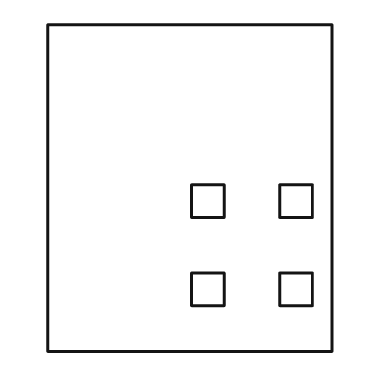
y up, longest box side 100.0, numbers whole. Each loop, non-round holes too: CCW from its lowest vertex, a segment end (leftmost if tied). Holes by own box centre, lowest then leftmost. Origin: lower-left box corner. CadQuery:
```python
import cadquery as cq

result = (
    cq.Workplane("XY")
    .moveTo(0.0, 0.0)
    .lineTo(87.0, 0.0)
    .lineTo(87.0, 100.0)
    .lineTo(0.0, 100.0)
    .close()
    .moveTo(44.0, 14.0)
    .lineTo(54.0, 14.0)
    .lineTo(54.0, 24.0)
    .lineTo(44.0, 24.0)
    .close()
    .moveTo(71.0, 14.0)
    .lineTo(81.0, 14.0)
    .lineTo(81.0, 24.0)
    .lineTo(71.0, 24.0)
    .close()
    .moveTo(44.0, 41.0)
    .lineTo(54.0, 41.0)
    .lineTo(54.0, 51.0)
    .lineTo(44.0, 51.0)
    .close()
    .moveTo(71.0, 41.0)
    .lineTo(81.0, 41.0)
    .lineTo(81.0, 51.0)
    .lineTo(71.0, 51.0)
    .close()
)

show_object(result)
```